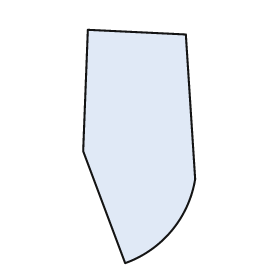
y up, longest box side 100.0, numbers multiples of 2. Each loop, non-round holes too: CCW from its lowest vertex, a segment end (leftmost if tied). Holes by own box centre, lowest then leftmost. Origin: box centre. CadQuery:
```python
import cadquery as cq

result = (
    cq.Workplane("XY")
    .moveTo(-6.0, -50.0)
    .threePointArc((14.0, -36.0), (24.0, -14.0))
    .lineTo(20.0, 48.0)
    .lineTo(-22.0, 50.0)
    .lineTo(-24.0, -2.0)
    .close()
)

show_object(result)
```